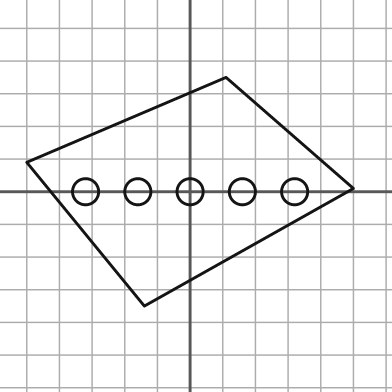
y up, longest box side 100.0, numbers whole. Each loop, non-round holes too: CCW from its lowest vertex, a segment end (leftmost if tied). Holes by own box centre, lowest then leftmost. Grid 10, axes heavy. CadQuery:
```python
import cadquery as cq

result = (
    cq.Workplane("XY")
    .moveTo(-14.0, -35.0)
    .lineTo(50.0, 1.0)
    .lineTo(11.0, 35.0)
    .lineTo(-50.0, 9.0)
    .close()
    .moveTo(-32.0, 0.0)
    .circle(4.0)
    .moveTo(-16.0, 0.0)
    .circle(4.0)
    .moveTo(0.0, 0.0)
    .circle(4.0)
    .moveTo(16.0, 0.0)
    .circle(4.0)
    .moveTo(32.0, 0.0)
    .circle(4.0)
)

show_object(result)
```